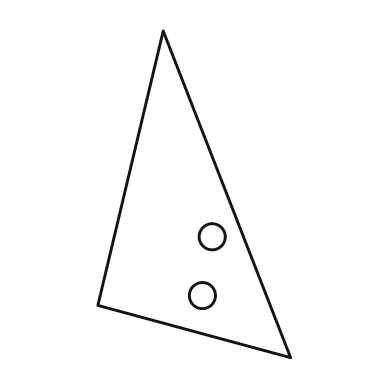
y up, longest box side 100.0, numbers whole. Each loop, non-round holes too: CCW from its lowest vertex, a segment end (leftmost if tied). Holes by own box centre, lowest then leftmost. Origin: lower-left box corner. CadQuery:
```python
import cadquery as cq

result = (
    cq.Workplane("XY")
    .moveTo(59.0, 0.0)
    .lineTo(20.0, 100.0)
    .lineTo(0.0, 16.0)
    .close()
    .moveTo(32.0, 19.0)
    .circle(4.0)
    .moveTo(35.0, 37.0)
    .circle(4.0)
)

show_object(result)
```